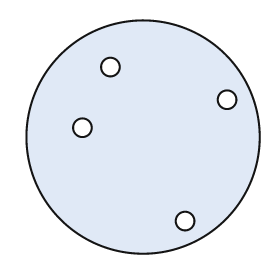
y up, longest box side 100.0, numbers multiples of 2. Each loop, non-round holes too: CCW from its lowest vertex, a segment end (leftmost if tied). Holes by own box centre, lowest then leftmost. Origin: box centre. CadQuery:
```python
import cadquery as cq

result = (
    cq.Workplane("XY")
    .moveTo(0.0, 0.0)
    .circle(50.0)
    .moveTo(18.0, -36.0)
    .circle(4.0)
    .moveTo(-26.0, 4.0)
    .circle(4.0)
    .moveTo(36.0, 16.0)
    .circle(4.0)
    .moveTo(-14.0, 30.0)
    .circle(4.0)
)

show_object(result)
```